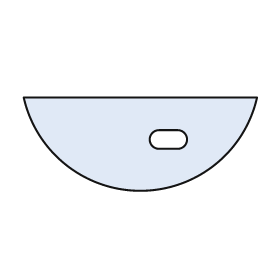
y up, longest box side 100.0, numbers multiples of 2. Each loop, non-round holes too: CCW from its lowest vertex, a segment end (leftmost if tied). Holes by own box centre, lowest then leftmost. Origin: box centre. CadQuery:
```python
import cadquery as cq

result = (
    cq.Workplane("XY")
    .moveTo(-50.0, 20.0)
    .threePointArc((0.0, -20.0), (50.0, 20.0))
    .close()
    .moveTo(8.0, -2.0)
    .lineTo(16.0, -2.0)
    .threePointArc((20.0, 2.0), (16.0, 6.0))
    .lineTo(8.0, 6.0)
    .threePointArc((4.0, 2.0), (8.0, -2.0))
    .close()
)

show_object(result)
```